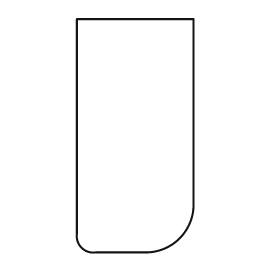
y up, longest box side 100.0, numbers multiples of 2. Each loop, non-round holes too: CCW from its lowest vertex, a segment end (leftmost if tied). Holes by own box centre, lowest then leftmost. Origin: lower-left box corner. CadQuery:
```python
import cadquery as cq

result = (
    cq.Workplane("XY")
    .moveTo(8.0, 0.0)
    .lineTo(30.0, 0.0)
    .threePointArc((44.0, 6.0), (50.0, 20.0))
    .lineTo(50.0, 100.0)
    .lineTo(0.0, 100.0)
    .lineTo(0.0, 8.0)
    .threePointArc((2.0, 2.0), (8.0, 0.0))
    .close()
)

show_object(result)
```